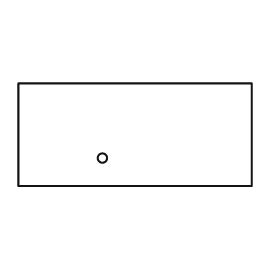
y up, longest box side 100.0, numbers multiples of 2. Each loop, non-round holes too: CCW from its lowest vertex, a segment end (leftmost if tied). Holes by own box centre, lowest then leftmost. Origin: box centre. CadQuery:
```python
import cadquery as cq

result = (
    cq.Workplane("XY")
    .moveTo(-50.0, -22.0)
    .lineTo(50.0, -22.0)
    .lineTo(50.0, 22.0)
    .lineTo(-50.0, 22.0)
    .close()
    .moveTo(-14.0, -10.0)
    .circle(2.0)
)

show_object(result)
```